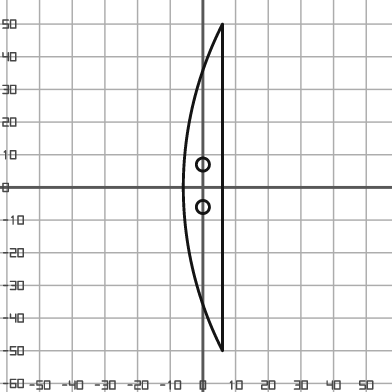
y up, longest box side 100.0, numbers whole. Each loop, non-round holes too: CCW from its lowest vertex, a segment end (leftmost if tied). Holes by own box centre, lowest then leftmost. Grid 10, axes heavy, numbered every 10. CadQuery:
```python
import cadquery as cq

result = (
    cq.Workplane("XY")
    .moveTo(6.0, -50.0)
    .lineTo(6.0, 50.0)
    .threePointArc((-6.0, 0.0), (6.0, -50.0))
    .close()
    .moveTo(0.0, -6.0)
    .circle(2.0)
    .moveTo(0.0, 7.0)
    .circle(2.0)
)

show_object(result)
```